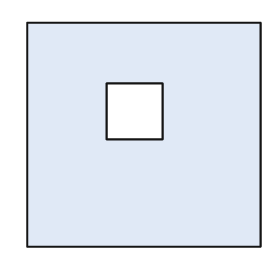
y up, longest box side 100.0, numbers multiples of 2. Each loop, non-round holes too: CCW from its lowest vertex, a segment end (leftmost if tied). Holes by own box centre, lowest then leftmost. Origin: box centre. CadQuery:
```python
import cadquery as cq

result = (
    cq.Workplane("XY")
    .moveTo(-50.0, -48.0)
    .lineTo(50.0, -48.0)
    .lineTo(50.0, 48.0)
    .lineTo(-50.0, 48.0)
    .close()
    .moveTo(-16.0, -2.0)
    .lineTo(8.0, -2.0)
    .lineTo(8.0, 22.0)
    .lineTo(-16.0, 22.0)
    .close()
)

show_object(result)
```